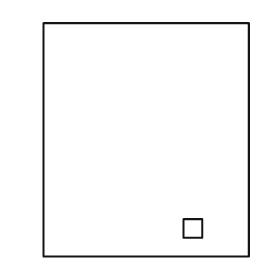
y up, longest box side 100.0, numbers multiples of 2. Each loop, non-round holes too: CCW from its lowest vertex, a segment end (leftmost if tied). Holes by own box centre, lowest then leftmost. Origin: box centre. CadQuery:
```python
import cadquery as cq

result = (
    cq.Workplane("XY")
    .moveTo(-44.0, -50.0)
    .lineTo(44.0, -50.0)
    .lineTo(44.0, 50.0)
    .lineTo(-44.0, 50.0)
    .close()
    .moveTo(16.0, -42.0)
    .lineTo(24.0, -42.0)
    .lineTo(24.0, -34.0)
    .lineTo(16.0, -34.0)
    .close()
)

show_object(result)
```